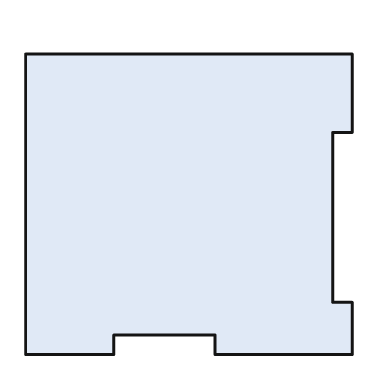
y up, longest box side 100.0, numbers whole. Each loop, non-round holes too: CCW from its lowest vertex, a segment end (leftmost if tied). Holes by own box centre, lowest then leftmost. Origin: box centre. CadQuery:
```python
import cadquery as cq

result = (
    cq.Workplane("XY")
    .moveTo(-50.0, -46.0)
    .lineTo(-23.0, -46.0)
    .lineTo(-23.0, -40.0)
    .lineTo(8.0, -40.0)
    .lineTo(8.0, -46.0)
    .lineTo(50.0, -46.0)
    .lineTo(50.0, -30.0)
    .lineTo(44.0, -30.0)
    .lineTo(44.0, 22.0)
    .lineTo(50.0, 22.0)
    .lineTo(50.0, 46.0)
    .lineTo(-50.0, 46.0)
    .close()
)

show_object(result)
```